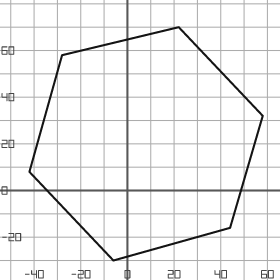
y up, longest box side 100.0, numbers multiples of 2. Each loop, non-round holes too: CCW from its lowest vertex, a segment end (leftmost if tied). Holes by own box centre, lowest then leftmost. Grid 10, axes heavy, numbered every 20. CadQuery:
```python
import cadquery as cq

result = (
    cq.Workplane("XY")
    .moveTo(-6.0, -30.0)
    .lineTo(44.0, -16.0)
    .lineTo(58.0, 32.0)
    .lineTo(22.0, 70.0)
    .lineTo(-28.0, 58.0)
    .lineTo(-42.0, 8.0)
    .close()
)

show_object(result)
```